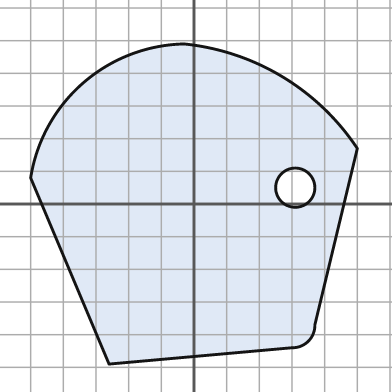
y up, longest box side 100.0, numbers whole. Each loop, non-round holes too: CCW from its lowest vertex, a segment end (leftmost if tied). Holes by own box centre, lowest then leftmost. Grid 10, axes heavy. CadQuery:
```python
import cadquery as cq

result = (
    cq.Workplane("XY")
    .moveTo(-26.0, -49.0)
    .lineTo(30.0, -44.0)
    .threePointArc((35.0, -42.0), (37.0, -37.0))
    .lineTo(50.0, 17.0)
    .threePointArc((27.0, 39.0), (-3.0, 49.0))
    .threePointArc((-34.0, 37.0), (-50.0, 8.0))
    .close()
    .moveTo(31.0, 5.0)
    .circle(6.0)
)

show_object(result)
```